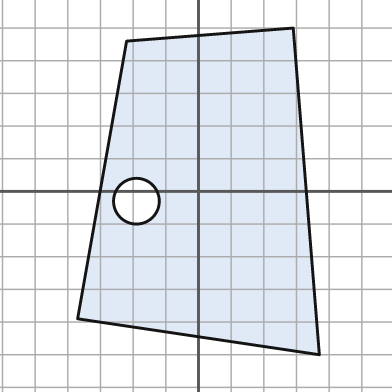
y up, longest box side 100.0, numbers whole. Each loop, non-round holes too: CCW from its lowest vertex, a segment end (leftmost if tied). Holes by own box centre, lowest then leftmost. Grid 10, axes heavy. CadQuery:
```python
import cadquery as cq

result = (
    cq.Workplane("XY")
    .moveTo(37.0, -50.0)
    .lineTo(29.0, 50.0)
    .lineTo(-22.0, 46.0)
    .lineTo(-37.0, -39.0)
    .close()
    .moveTo(-19.0, -3.0)
    .circle(7.0)
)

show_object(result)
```